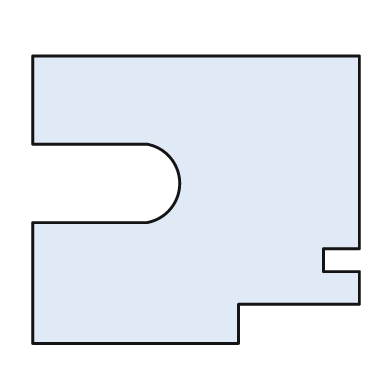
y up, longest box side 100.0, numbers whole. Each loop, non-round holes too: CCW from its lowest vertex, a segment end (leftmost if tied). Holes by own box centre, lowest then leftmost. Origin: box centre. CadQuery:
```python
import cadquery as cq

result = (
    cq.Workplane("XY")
    .moveTo(-50.0, -44.0)
    .lineTo(13.0, -44.0)
    .lineTo(13.0, -32.0)
    .lineTo(50.0, -32.0)
    .lineTo(50.0, -22.0)
    .lineTo(39.0, -22.0)
    .lineTo(39.0, -15.0)
    .lineTo(50.0, -15.0)
    .lineTo(50.0, 44.0)
    .lineTo(-50.0, 44.0)
    .lineTo(-50.0, 17.0)
    .lineTo(-15.0, 17.0)
    .threePointArc((-5.0, 5.0), (-15.0, -7.0))
    .lineTo(-50.0, -7.0)
    .close()
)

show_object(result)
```